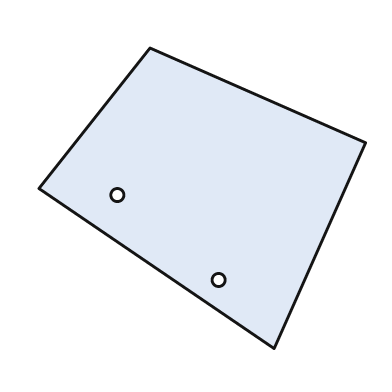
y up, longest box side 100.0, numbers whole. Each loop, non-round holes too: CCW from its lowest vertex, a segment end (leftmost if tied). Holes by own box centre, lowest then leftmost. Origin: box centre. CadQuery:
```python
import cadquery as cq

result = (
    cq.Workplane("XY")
    .moveTo(22.0, -46.0)
    .lineTo(50.0, 17.0)
    .lineTo(-16.0, 46.0)
    .lineTo(-50.0, 3.0)
    .close()
    .moveTo(5.0, -25.0)
    .circle(2.0)
    .moveTo(-26.0, 1.0)
    .circle(2.0)
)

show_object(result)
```